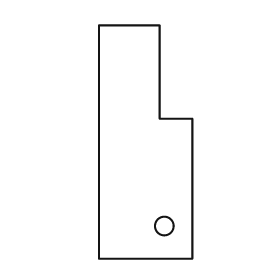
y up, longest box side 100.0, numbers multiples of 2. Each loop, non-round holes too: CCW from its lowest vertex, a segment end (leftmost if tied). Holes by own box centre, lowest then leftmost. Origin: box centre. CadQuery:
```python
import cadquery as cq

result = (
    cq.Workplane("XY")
    .moveTo(-20.0, -50.0)
    .lineTo(20.0, -50.0)
    .lineTo(20.0, 10.0)
    .lineTo(6.0, 10.0)
    .lineTo(6.0, 50.0)
    .lineTo(-20.0, 50.0)
    .close()
    .moveTo(8.0, -36.0)
    .circle(4.0)
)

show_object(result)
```